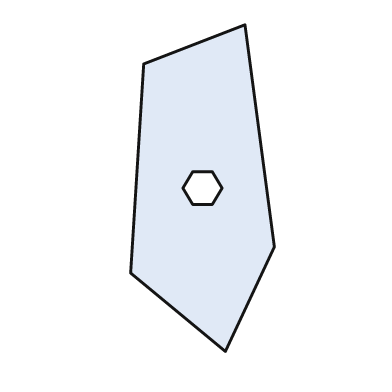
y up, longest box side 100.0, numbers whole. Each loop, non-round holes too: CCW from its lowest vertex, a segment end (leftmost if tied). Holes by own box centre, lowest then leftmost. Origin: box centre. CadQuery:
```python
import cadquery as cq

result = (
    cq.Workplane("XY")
    .moveTo(7.0, -50.0)
    .lineTo(22.0, -18.0)
    .lineTo(13.0, 50.0)
    .lineTo(-18.0, 38.0)
    .lineTo(-22.0, -26.0)
    .close()
    .moveTo(-3.0, -5.0)
    .lineTo(3.0, -5.0)
    .lineTo(6.0, 0.0)
    .lineTo(3.0, 5.0)
    .lineTo(-3.0, 5.0)
    .lineTo(-6.0, 0.0)
    .close()
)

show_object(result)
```